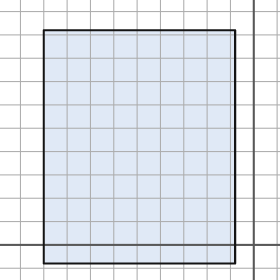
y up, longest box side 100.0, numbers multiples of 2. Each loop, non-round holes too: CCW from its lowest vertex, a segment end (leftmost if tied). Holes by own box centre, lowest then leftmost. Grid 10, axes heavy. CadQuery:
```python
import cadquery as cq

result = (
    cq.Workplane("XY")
    .moveTo(-90.0, -8.0)
    .lineTo(-8.0, -8.0)
    .lineTo(-8.0, 92.0)
    .lineTo(-90.0, 92.0)
    .close()
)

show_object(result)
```